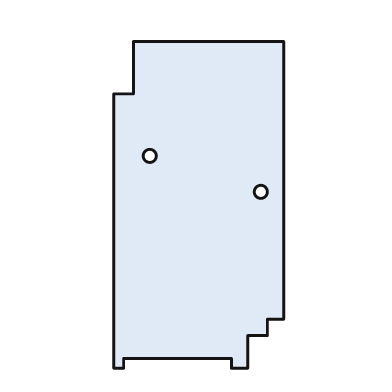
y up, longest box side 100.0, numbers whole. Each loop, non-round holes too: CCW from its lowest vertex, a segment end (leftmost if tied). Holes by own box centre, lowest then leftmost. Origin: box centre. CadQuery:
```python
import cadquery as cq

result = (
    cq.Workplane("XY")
    .moveTo(-26.0, -50.0)
    .lineTo(-23.0, -50.0)
    .lineTo(-23.0, -47.0)
    .lineTo(10.0, -47.0)
    .lineTo(10.0, -50.0)
    .lineTo(15.0, -50.0)
    .lineTo(15.0, -40.0)
    .lineTo(21.0, -40.0)
    .lineTo(21.0, -35.0)
    .lineTo(26.0, -35.0)
    .lineTo(26.0, 50.0)
    .lineTo(-20.0, 50.0)
    .lineTo(-20.0, 34.0)
    .lineTo(-26.0, 34.0)
    .close()
    .moveTo(19.0, 4.0)
    .circle(2.0)
    .moveTo(-15.0, 15.0)
    .circle(2.0)
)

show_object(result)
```